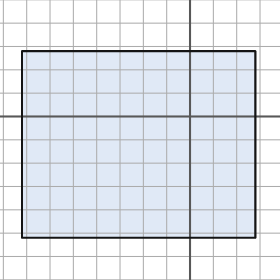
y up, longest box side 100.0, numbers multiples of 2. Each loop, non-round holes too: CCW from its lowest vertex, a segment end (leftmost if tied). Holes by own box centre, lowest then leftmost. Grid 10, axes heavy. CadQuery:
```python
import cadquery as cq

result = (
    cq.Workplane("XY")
    .moveTo(-72.0, -52.0)
    .lineTo(28.0, -52.0)
    .lineTo(28.0, 28.0)
    .lineTo(-72.0, 28.0)
    .close()
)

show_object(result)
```